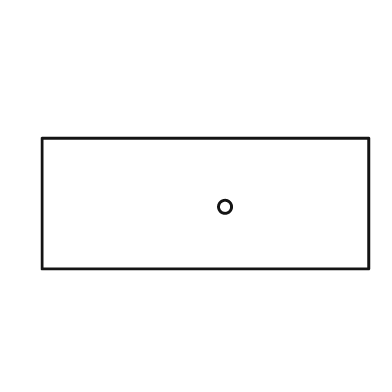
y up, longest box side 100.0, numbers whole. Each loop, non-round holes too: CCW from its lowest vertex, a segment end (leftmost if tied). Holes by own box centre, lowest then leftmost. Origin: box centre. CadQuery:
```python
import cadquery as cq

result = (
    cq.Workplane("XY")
    .moveTo(-50.0, -20.0)
    .lineTo(50.0, -20.0)
    .lineTo(50.0, 20.0)
    .lineTo(-50.0, 20.0)
    .close()
    .moveTo(6.0, -1.0)
    .circle(2.0)
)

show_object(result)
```